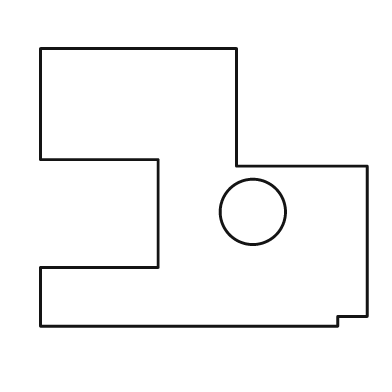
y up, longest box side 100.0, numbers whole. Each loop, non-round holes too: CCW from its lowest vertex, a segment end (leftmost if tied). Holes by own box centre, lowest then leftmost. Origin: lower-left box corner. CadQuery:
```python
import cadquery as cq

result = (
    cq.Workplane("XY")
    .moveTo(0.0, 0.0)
    .lineTo(91.0, 0.0)
    .lineTo(91.0, 3.0)
    .lineTo(100.0, 3.0)
    .lineTo(100.0, 49.0)
    .lineTo(60.0, 49.0)
    .lineTo(60.0, 85.0)
    .lineTo(0.0, 85.0)
    .lineTo(0.0, 51.0)
    .lineTo(36.0, 51.0)
    .lineTo(36.0, 18.0)
    .lineTo(0.0, 18.0)
    .close()
    .moveTo(65.0, 35.0)
    .circle(10.0)
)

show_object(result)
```